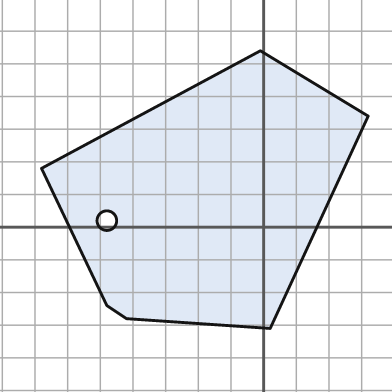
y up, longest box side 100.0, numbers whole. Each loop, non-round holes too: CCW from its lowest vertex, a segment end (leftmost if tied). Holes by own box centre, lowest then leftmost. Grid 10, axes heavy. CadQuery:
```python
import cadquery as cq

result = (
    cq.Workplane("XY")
    .moveTo(2.0, -31.0)
    .lineTo(32.0, 34.0)
    .lineTo(-1.0, 54.0)
    .lineTo(-68.0, 18.0)
    .lineTo(-48.0, -24.0)
    .lineTo(-42.0, -28.0)
    .close()
    .moveTo(-48.0, 2.0)
    .circle(3.0)
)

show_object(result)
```